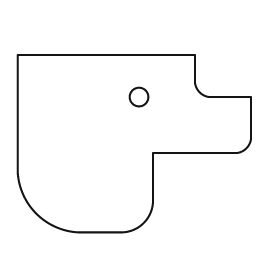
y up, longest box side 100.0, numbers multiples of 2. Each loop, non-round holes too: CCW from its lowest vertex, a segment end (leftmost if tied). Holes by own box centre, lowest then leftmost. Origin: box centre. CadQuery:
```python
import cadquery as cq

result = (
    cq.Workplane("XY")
    .moveTo(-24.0, -38.0)
    .lineTo(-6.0, -38.0)
    .threePointArc((4.0, -34.0), (8.0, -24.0))
    .lineTo(8.0, -4.0)
    .lineTo(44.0, -4.0)
    .threePointArc((48.0, -2.0), (50.0, 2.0))
    .lineTo(50.0, 20.0)
    .lineTo(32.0, 20.0)
    .threePointArc((28.0, 22.0), (26.0, 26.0))
    .lineTo(26.0, 38.0)
    .lineTo(-50.0, 38.0)
    .lineTo(-50.0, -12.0)
    .threePointArc((-42.0, -30.0), (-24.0, -38.0))
    .close()
    .moveTo(2.0, 20.0)
    .circle(4.0)
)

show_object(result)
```